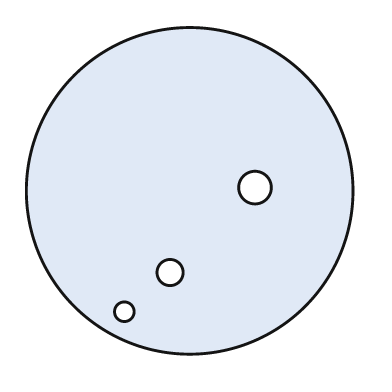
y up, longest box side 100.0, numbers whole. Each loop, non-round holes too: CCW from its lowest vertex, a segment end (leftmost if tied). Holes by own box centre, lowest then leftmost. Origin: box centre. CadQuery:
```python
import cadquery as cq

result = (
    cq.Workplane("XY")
    .moveTo(0.0, 0.0)
    .circle(50.0)
    .moveTo(-20.0, -37.0)
    .circle(3.0)
    .moveTo(-6.0, -25.0)
    .circle(4.0)
    .moveTo(20.0, 1.0)
    .circle(5.0)
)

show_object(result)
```